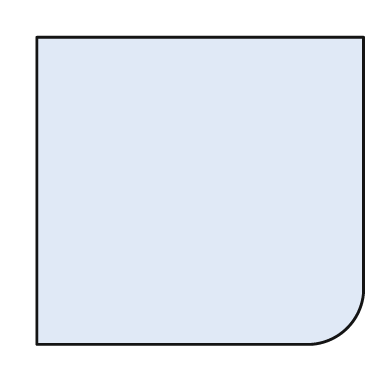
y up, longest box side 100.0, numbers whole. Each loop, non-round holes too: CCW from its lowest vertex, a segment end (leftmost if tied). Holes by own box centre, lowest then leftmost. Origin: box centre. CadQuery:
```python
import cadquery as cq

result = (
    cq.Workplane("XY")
    .moveTo(-50.0, -47.0)
    .lineTo(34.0, -47.0)
    .threePointArc((45.0, -42.0), (50.0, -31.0))
    .lineTo(50.0, 47.0)
    .lineTo(-50.0, 47.0)
    .close()
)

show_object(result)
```